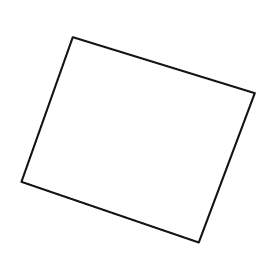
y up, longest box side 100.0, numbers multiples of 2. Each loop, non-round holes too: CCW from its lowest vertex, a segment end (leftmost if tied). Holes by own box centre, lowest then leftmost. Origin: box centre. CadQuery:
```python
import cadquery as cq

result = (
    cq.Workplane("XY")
    .moveTo(26.0, -44.0)
    .lineTo(50.0, 20.0)
    .lineTo(-28.0, 44.0)
    .lineTo(-50.0, -18.0)
    .close()
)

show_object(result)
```